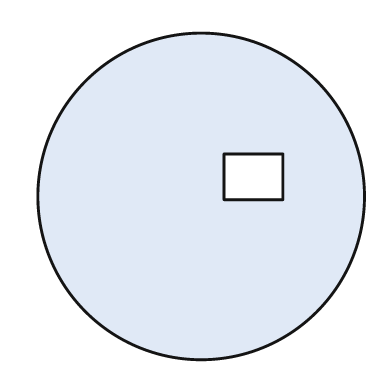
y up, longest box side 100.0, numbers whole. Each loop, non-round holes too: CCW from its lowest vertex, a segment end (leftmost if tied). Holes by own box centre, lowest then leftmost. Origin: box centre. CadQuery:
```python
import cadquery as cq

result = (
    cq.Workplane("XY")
    .moveTo(0.0, 0.0)
    .circle(50.0)
    .moveTo(7.0, -1.0)
    .lineTo(25.0, -1.0)
    .lineTo(25.0, 13.0)
    .lineTo(7.0, 13.0)
    .close()
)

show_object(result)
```